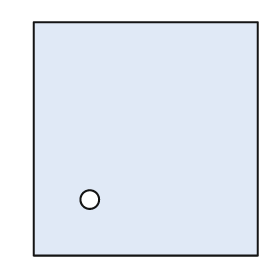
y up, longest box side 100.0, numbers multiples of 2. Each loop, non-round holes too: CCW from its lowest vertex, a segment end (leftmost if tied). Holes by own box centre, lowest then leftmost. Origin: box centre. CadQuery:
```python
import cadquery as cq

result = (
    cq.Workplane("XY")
    .moveTo(-48.0, -50.0)
    .lineTo(48.0, -50.0)
    .lineTo(48.0, 50.0)
    .lineTo(-48.0, 50.0)
    .close()
    .moveTo(-24.0, -26.0)
    .circle(4.0)
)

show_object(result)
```